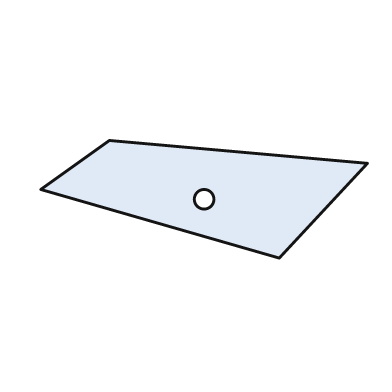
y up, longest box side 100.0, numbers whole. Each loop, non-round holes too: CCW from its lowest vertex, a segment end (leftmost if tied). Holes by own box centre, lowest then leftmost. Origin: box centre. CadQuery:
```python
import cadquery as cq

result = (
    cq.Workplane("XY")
    .moveTo(23.0, -18.0)
    .lineTo(50.0, 11.0)
    .lineTo(-29.0, 18.0)
    .lineTo(-50.0, 3.0)
    .close()
    .moveTo(0.0, 0.0)
    .circle(3.0)
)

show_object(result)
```